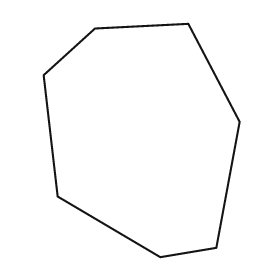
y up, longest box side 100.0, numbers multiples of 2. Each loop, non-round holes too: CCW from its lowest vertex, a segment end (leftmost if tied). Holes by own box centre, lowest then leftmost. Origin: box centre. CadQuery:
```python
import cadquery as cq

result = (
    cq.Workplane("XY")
    .moveTo(8.0, -50.0)
    .lineTo(32.0, -46.0)
    .lineTo(42.0, 8.0)
    .lineTo(20.0, 50.0)
    .lineTo(-20.0, 48.0)
    .lineTo(-42.0, 28.0)
    .lineTo(-36.0, -24.0)
    .close()
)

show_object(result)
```